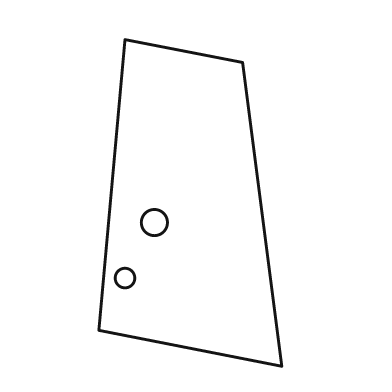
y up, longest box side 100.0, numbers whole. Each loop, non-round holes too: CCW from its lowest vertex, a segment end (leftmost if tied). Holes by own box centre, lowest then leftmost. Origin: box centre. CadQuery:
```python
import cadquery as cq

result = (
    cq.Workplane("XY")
    .moveTo(28.0, -50.0)
    .lineTo(16.0, 43.0)
    .lineTo(-20.0, 50.0)
    .lineTo(-28.0, -39.0)
    .close()
    .moveTo(-20.0, -23.0)
    .circle(3.0)
    .moveTo(-11.0, -6.0)
    .circle(4.0)
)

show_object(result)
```